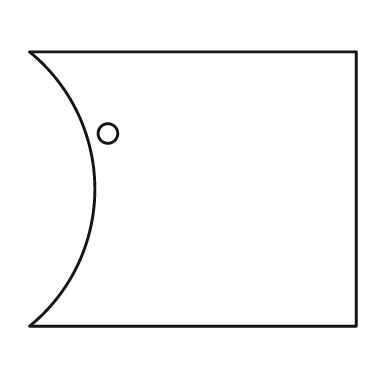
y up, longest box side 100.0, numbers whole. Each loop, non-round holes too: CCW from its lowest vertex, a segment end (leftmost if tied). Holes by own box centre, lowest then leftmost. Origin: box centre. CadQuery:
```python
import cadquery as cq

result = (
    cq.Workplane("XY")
    .moveTo(-50.0, -42.0)
    .lineTo(50.0, -42.0)
    .lineTo(50.0, 42.0)
    .lineTo(-50.0, 42.0)
    .threePointArc((-30.0, 0.0), (-50.0, -42.0))
    .close()
    .moveTo(-26.0, 17.0)
    .circle(3.0)
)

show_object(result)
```